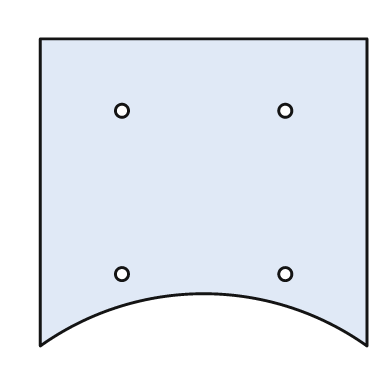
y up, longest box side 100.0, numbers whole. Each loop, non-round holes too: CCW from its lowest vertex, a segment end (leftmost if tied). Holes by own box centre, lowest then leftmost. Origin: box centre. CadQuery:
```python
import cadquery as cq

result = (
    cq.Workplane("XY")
    .moveTo(-50.0, -47.0)
    .threePointArc((0.0, -31.0), (50.0, -47.0))
    .lineTo(50.0, 47.0)
    .lineTo(-50.0, 47.0)
    .close()
    .moveTo(-25.0, -25.0)
    .circle(2.0)
    .moveTo(25.0, -25.0)
    .circle(2.0)
    .moveTo(-25.0, 25.0)
    .circle(2.0)
    .moveTo(25.0, 25.0)
    .circle(2.0)
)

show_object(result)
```